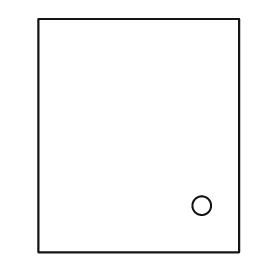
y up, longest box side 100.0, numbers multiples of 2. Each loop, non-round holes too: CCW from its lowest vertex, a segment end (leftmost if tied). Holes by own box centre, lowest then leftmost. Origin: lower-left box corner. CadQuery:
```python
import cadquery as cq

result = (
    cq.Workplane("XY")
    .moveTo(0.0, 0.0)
    .lineTo(86.0, 0.0)
    .lineTo(86.0, 100.0)
    .lineTo(0.0, 100.0)
    .close()
    .moveTo(70.0, 20.0)
    .circle(4.0)
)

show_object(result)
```